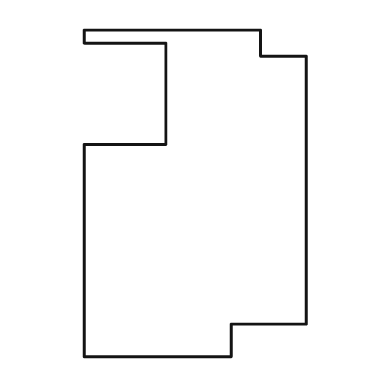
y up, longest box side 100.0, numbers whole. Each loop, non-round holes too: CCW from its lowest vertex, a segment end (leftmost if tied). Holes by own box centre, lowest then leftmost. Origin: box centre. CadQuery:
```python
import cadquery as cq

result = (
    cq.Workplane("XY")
    .moveTo(-34.0, -50.0)
    .lineTo(11.0, -50.0)
    .lineTo(11.0, -40.0)
    .lineTo(34.0, -40.0)
    .lineTo(34.0, 42.0)
    .lineTo(20.0, 42.0)
    .lineTo(20.0, 50.0)
    .lineTo(-34.0, 50.0)
    .lineTo(-34.0, 46.0)
    .lineTo(-9.0, 46.0)
    .lineTo(-9.0, 15.0)
    .lineTo(-34.0, 15.0)
    .close()
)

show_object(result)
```